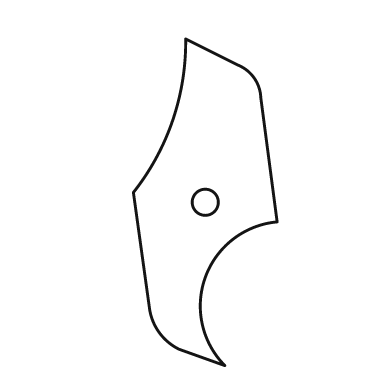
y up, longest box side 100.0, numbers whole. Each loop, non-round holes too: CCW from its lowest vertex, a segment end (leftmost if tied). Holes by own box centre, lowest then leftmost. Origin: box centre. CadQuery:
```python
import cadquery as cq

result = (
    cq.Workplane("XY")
    .moveTo(6.0, -50.0)
    .threePointArc((0.0, -23.0), (22.0, -6.0))
    .lineTo(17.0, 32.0)
    .threePointArc((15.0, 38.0), (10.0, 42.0))
    .lineTo(-6.0, 50.0)
    .threePointArc((-10.0, 25.0), (-22.0, 3.0))
    .lineTo(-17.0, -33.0)
    .threePointArc((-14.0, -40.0), (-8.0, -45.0))
    .close()
    .moveTo(0.0, 0.0)
    .circle(4.0)
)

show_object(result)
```